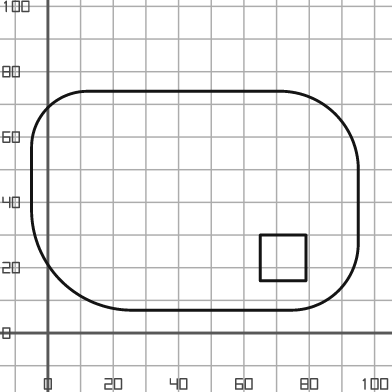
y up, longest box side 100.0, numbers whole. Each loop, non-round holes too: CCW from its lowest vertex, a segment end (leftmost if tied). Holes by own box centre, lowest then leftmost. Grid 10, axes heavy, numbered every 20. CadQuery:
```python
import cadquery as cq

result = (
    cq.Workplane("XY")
    .moveTo(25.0, 7.0)
    .lineTo(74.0, 7.0)
    .threePointArc((89.0, 13.0), (95.0, 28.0))
    .lineTo(95.0, 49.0)
    .threePointArc((88.0, 67.0), (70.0, 74.0))
    .lineTo(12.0, 74.0)
    .threePointArc((0.0, 69.0), (-5.0, 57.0))
    .lineTo(-5.0, 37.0)
    .threePointArc((4.0, 16.0), (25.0, 7.0))
    .close()
    .moveTo(65.0, 16.0)
    .lineTo(79.0, 16.0)
    .lineTo(79.0, 30.0)
    .lineTo(65.0, 30.0)
    .close()
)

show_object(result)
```